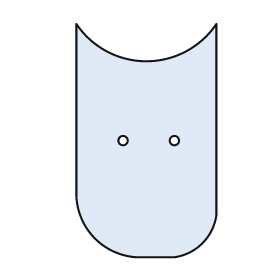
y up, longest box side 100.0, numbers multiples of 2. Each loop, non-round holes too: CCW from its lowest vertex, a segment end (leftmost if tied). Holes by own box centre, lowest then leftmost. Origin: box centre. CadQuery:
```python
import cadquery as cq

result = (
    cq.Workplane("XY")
    .moveTo(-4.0, -50.0)
    .lineTo(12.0, -50.0)
    .threePointArc((24.0, -44.0), (30.0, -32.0))
    .lineTo(30.0, 50.0)
    .threePointArc((0.0, 34.0), (-30.0, 50.0))
    .lineTo(-30.0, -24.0)
    .threePointArc((-22.0, -42.0), (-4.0, -50.0))
    .close()
    .moveTo(-10.0, 0.0)
    .circle(2.0)
    .moveTo(12.0, 0.0)
    .circle(2.0)
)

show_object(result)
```